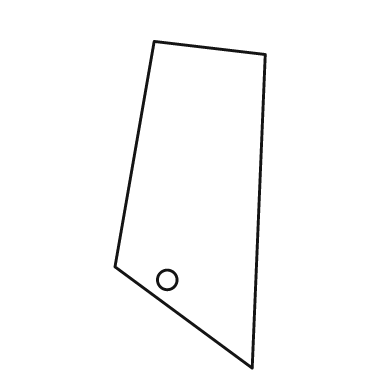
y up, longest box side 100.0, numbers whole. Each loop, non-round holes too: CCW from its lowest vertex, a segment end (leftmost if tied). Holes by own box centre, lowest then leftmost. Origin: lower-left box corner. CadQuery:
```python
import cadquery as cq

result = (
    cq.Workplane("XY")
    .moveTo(42.0, 0.0)
    .lineTo(46.0, 96.0)
    .lineTo(12.0, 100.0)
    .lineTo(0.0, 31.0)
    .close()
    .moveTo(16.0, 27.0)
    .circle(3.0)
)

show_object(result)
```